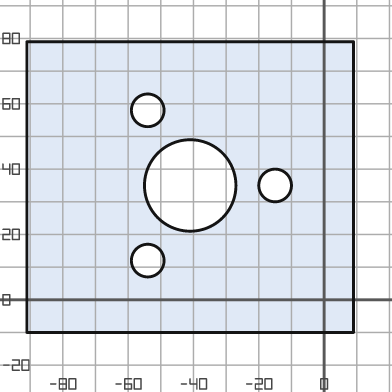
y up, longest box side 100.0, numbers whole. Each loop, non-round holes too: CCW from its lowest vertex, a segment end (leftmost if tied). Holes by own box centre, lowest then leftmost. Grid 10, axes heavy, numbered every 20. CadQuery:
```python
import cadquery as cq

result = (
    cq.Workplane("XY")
    .moveTo(-91.0, -10.0)
    .lineTo(9.0, -10.0)
    .lineTo(9.0, 79.0)
    .lineTo(-91.0, 79.0)
    .close()
    .moveTo(-54.0, 12.0)
    .circle(5.0)
    .moveTo(-41.0, 35.0)
    .circle(14.0)
    .moveTo(-15.0, 35.0)
    .circle(5.0)
    .moveTo(-54.0, 58.0)
    .circle(5.0)
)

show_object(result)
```